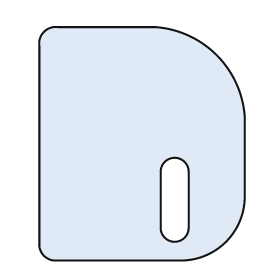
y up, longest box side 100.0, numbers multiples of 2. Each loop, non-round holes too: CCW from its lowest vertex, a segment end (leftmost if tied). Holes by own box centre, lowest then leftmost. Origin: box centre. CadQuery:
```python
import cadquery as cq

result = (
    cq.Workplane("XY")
    .moveTo(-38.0, -50.0)
    .lineTo(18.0, -50.0)
    .threePointArc((36.0, -42.0), (44.0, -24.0))
    .lineTo(44.0, 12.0)
    .threePointArc((32.0, 38.0), (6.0, 50.0))
    .lineTo(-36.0, 50.0)
    .threePointArc((-42.0, 48.0), (-44.0, 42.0))
    .lineTo(-44.0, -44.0)
    .threePointArc((-42.0, -48.0), (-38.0, -50.0))
    .close()
    .moveTo(8.0, -36.0)
    .threePointArc((14.0, -42.0), (20.0, -36.0))
    .lineTo(20.0, -12.0)
    .threePointArc((14.0, -6.0), (8.0, -12.0))
    .close()
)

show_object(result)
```